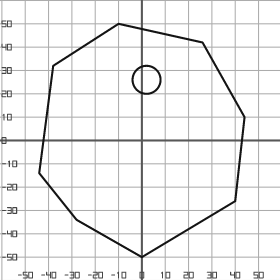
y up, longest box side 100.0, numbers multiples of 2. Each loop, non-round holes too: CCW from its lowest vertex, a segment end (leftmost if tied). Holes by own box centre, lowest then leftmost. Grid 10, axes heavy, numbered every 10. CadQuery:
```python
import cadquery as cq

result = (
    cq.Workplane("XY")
    .moveTo(0.0, -50.0)
    .lineTo(40.0, -26.0)
    .lineTo(44.0, 10.0)
    .lineTo(26.0, 42.0)
    .lineTo(-10.0, 50.0)
    .lineTo(-38.0, 32.0)
    .lineTo(-44.0, -14.0)
    .lineTo(-28.0, -34.0)
    .close()
    .moveTo(2.0, 26.0)
    .circle(6.0)
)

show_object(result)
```